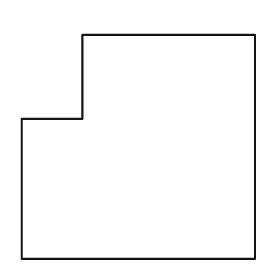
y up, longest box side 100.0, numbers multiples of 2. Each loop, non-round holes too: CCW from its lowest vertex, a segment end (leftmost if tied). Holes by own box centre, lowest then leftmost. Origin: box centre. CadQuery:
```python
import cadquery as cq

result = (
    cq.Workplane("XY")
    .moveTo(-50.0, -48.0)
    .lineTo(50.0, -48.0)
    .lineTo(50.0, 48.0)
    .lineTo(-24.0, 48.0)
    .lineTo(-24.0, 12.0)
    .lineTo(-50.0, 12.0)
    .close()
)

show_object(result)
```